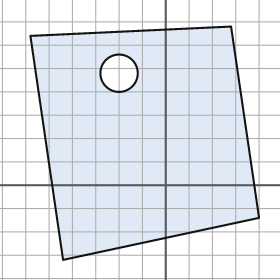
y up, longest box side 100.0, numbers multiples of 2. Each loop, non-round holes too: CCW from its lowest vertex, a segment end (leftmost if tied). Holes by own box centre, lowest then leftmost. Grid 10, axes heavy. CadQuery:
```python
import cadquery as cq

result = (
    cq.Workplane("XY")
    .moveTo(-44.0, -32.0)
    .lineTo(40.0, -14.0)
    .lineTo(28.0, 68.0)
    .lineTo(-58.0, 64.0)
    .close()
    .moveTo(-20.0, 48.0)
    .circle(8.0)
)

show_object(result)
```